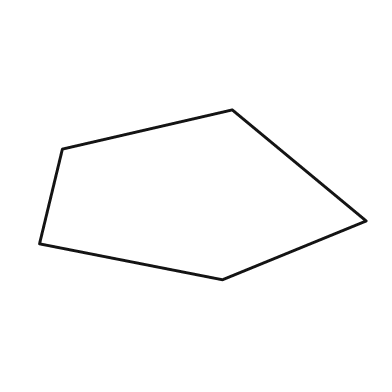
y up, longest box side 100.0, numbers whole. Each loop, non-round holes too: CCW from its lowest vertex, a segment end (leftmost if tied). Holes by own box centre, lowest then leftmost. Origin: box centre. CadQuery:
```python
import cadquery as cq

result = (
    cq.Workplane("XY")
    .moveTo(6.0, -26.0)
    .lineTo(50.0, -8.0)
    .lineTo(9.0, 26.0)
    .lineTo(-43.0, 14.0)
    .lineTo(-50.0, -15.0)
    .close()
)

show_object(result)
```